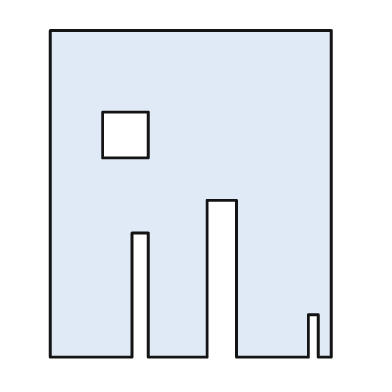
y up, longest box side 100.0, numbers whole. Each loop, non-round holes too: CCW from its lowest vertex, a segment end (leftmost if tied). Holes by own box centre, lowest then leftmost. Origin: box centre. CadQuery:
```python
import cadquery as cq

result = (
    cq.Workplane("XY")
    .moveTo(-43.0, -50.0)
    .lineTo(-18.0, -50.0)
    .lineTo(-18.0, -12.0)
    .lineTo(-13.0, -12.0)
    .lineTo(-13.0, -50.0)
    .lineTo(5.0, -50.0)
    .lineTo(5.0, -2.0)
    .lineTo(14.0, -2.0)
    .lineTo(14.0, -50.0)
    .lineTo(36.0, -50.0)
    .lineTo(36.0, -37.0)
    .lineTo(39.0, -37.0)
    .lineTo(39.0, -50.0)
    .lineTo(43.0, -50.0)
    .lineTo(43.0, 50.0)
    .lineTo(-43.0, 50.0)
    .close()
    .moveTo(-27.0, 11.0)
    .lineTo(-13.0, 11.0)
    .lineTo(-13.0, 25.0)
    .lineTo(-27.0, 25.0)
    .close()
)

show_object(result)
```